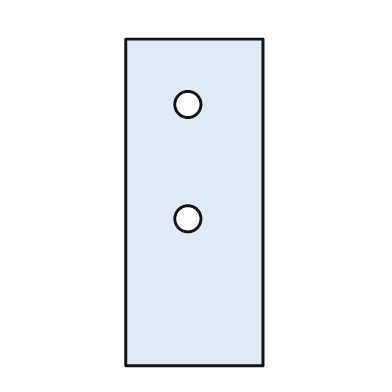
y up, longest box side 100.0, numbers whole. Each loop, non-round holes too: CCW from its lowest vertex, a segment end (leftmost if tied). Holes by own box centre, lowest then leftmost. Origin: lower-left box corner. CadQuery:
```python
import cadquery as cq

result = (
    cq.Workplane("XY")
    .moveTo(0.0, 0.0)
    .lineTo(42.0, 0.0)
    .lineTo(42.0, 100.0)
    .lineTo(0.0, 100.0)
    .close()
    .moveTo(19.0, 45.0)
    .circle(4.0)
    .moveTo(19.0, 80.0)
    .circle(4.0)
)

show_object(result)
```